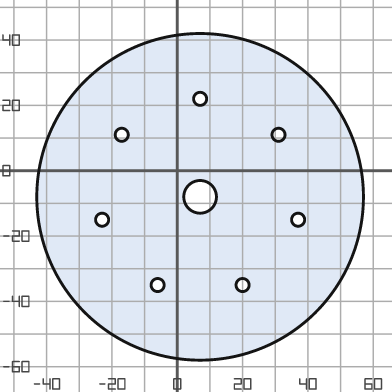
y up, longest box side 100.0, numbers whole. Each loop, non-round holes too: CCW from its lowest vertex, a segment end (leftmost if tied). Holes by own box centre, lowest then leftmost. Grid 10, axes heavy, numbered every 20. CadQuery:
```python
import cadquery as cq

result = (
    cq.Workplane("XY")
    .moveTo(7.0, -8.0)
    .circle(50.0)
    .moveTo(-6.0, -35.0)
    .circle(2.0)
    .moveTo(20.0, -35.0)
    .circle(2.0)
    .moveTo(-23.0, -15.0)
    .circle(2.0)
    .moveTo(37.0, -15.0)
    .circle(2.0)
    .moveTo(7.0, -8.0)
    .circle(5.0)
    .moveTo(-17.0, 11.0)
    .circle(2.0)
    .moveTo(31.0, 11.0)
    .circle(2.0)
    .moveTo(7.0, 22.0)
    .circle(2.0)
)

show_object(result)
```